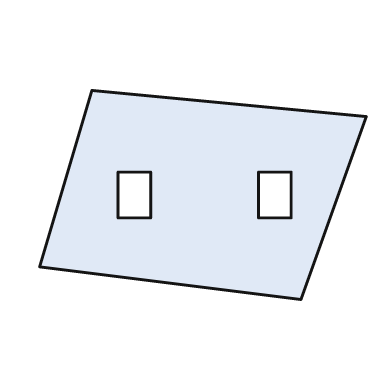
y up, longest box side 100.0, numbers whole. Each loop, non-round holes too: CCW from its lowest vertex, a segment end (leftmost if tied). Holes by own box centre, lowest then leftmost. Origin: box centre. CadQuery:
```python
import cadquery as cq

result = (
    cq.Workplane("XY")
    .moveTo(30.0, -32.0)
    .lineTo(50.0, 24.0)
    .lineTo(-34.0, 32.0)
    .lineTo(-50.0, -22.0)
    .close()
    .moveTo(-26.0, -7.0)
    .lineTo(-16.0, -7.0)
    .lineTo(-16.0, 7.0)
    .lineTo(-26.0, 7.0)
    .close()
    .moveTo(17.0, -7.0)
    .lineTo(27.0, -7.0)
    .lineTo(27.0, 7.0)
    .lineTo(17.0, 7.0)
    .close()
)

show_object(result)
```